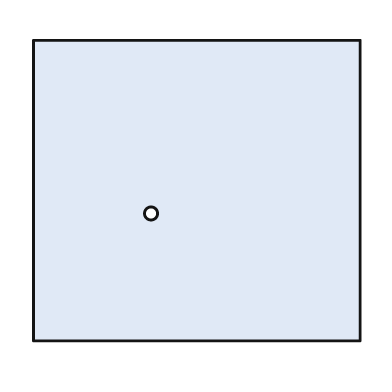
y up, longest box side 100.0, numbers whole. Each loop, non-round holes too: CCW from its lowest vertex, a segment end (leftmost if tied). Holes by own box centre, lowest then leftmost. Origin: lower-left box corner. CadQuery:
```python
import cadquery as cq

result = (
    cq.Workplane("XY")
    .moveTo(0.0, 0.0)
    .lineTo(100.0, 0.0)
    .lineTo(100.0, 92.0)
    .lineTo(0.0, 92.0)
    .close()
    .moveTo(36.0, 39.0)
    .circle(2.0)
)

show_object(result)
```